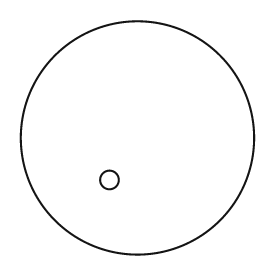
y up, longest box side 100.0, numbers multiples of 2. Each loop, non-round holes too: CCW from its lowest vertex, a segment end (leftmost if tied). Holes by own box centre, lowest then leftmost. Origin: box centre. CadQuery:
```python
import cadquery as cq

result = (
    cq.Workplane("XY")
    .moveTo(0.0, 0.0)
    .circle(50.0)
    .moveTo(-12.0, -18.0)
    .circle(4.0)
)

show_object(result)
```